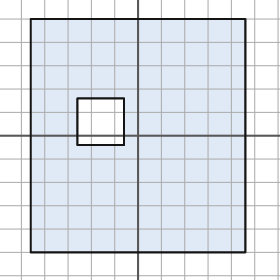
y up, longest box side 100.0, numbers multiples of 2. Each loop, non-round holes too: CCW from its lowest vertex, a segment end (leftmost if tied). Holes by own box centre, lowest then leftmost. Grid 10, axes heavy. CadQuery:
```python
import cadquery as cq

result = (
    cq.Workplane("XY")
    .moveTo(-46.0, -50.0)
    .lineTo(46.0, -50.0)
    .lineTo(46.0, 50.0)
    .lineTo(-46.0, 50.0)
    .close()
    .moveTo(-26.0, -4.0)
    .lineTo(-6.0, -4.0)
    .lineTo(-6.0, 16.0)
    .lineTo(-26.0, 16.0)
    .close()
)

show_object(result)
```